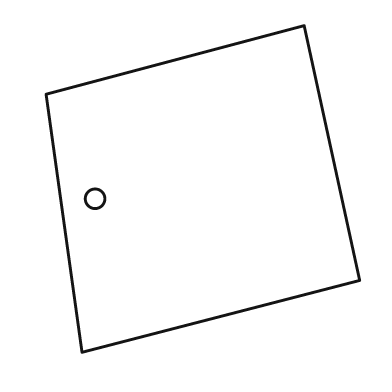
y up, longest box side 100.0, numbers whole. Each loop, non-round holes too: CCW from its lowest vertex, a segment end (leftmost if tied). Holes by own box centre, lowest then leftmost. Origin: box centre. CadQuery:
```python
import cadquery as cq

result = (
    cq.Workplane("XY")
    .moveTo(-37.0, -50.0)
    .lineTo(48.0, -28.0)
    .lineTo(31.0, 50.0)
    .lineTo(-48.0, 29.0)
    .close()
    .moveTo(-33.0, -3.0)
    .circle(3.0)
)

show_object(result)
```